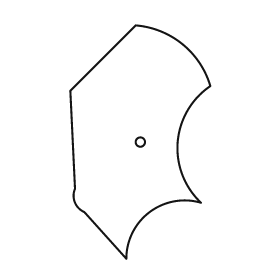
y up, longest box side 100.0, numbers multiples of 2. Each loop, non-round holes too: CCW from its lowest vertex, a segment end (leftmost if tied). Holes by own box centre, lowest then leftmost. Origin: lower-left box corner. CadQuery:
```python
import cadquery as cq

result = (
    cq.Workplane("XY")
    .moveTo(24.0, 0.0)
    .threePointArc((34.0, 20.0), (56.0, 24.0))
    .threePointArc((46.0, 50.0), (60.0, 74.0))
    .threePointArc((48.0, 92.0), (28.0, 100.0))
    .lineTo(0.0, 72.0)
    .lineTo(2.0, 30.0)
    .threePointArc((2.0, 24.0), (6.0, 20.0))
    .close()
    .moveTo(30.0, 50.0)
    .circle(2.0)
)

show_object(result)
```